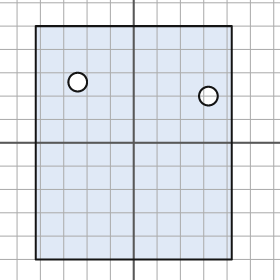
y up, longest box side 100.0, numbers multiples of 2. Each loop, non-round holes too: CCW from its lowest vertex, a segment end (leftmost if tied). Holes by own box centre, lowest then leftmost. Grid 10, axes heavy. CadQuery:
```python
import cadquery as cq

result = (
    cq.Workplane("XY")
    .moveTo(-42.0, -50.0)
    .lineTo(42.0, -50.0)
    .lineTo(42.0, 50.0)
    .lineTo(-42.0, 50.0)
    .close()
    .moveTo(32.0, 20.0)
    .circle(4.0)
    .moveTo(-24.0, 26.0)
    .circle(4.0)
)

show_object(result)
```